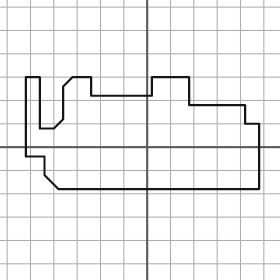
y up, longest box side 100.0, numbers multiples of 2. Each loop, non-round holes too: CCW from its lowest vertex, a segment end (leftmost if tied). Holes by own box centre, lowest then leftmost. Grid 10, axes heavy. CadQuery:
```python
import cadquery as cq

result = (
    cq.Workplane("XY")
    .moveTo(-38.0, -18.0)
    .lineTo(48.0, -18.0)
    .lineTo(48.0, 10.0)
    .lineTo(42.0, 10.0)
    .lineTo(42.0, 18.0)
    .lineTo(18.0, 18.0)
    .lineTo(18.0, 30.0)
    .lineTo(2.0, 30.0)
    .lineTo(2.0, 22.0)
    .lineTo(-24.0, 22.0)
    .lineTo(-24.0, 30.0)
    .lineTo(-32.0, 30.0)
    .lineTo(-36.0, 26.0)
    .lineTo(-36.0, 12.0)
    .lineTo(-40.0, 8.0)
    .lineTo(-46.0, 8.0)
    .lineTo(-46.0, 30.0)
    .lineTo(-52.0, 30.0)
    .lineTo(-52.0, -4.0)
    .lineTo(-44.0, -4.0)
    .lineTo(-44.0, -12.0)
    .close()
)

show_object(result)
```